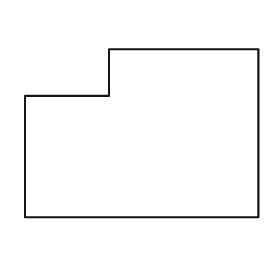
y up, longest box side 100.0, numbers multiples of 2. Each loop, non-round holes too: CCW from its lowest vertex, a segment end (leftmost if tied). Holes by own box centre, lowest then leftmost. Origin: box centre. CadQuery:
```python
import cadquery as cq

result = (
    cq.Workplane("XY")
    .moveTo(-50.0, -36.0)
    .lineTo(50.0, -36.0)
    .lineTo(50.0, 36.0)
    .lineTo(-14.0, 36.0)
    .lineTo(-14.0, 16.0)
    .lineTo(-50.0, 16.0)
    .close()
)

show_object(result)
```